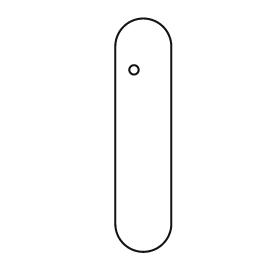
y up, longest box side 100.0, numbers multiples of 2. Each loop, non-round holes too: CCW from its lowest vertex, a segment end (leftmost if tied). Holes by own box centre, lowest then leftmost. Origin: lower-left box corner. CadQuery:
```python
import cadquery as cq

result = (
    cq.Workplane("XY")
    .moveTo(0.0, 12.0)
    .threePointArc((12.0, 0.0), (24.0, 12.0))
    .lineTo(24.0, 88.0)
    .threePointArc((12.0, 100.0), (0.0, 88.0))
    .close()
    .moveTo(8.0, 78.0)
    .circle(2.0)
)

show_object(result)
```